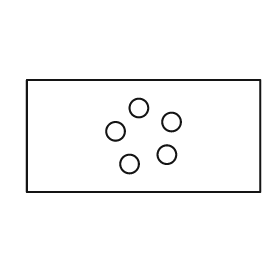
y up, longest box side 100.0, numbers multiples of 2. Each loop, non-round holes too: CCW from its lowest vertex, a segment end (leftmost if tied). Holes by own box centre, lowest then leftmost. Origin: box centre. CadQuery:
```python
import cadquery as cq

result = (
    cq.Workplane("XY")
    .moveTo(-50.0, -24.0)
    .lineTo(50.0, -24.0)
    .lineTo(50.0, 24.0)
    .lineTo(-50.0, 24.0)
    .close()
    .moveTo(-6.0, -12.0)
    .circle(4.0)
    .moveTo(10.0, -8.0)
    .circle(4.0)
    .moveTo(-12.0, 2.0)
    .circle(4.0)
    .moveTo(12.0, 6.0)
    .circle(4.0)
    .moveTo(-2.0, 12.0)
    .circle(4.0)
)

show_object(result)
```